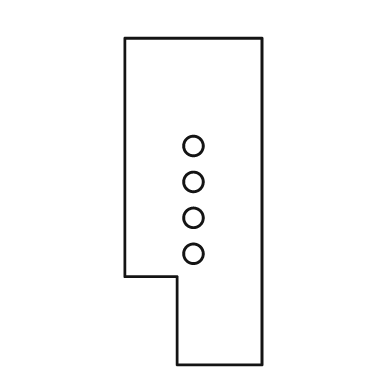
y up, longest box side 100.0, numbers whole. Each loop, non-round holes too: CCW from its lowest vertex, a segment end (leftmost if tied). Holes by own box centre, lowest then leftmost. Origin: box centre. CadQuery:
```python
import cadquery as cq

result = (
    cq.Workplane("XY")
    .moveTo(-5.0, -50.0)
    .lineTo(21.0, -50.0)
    .lineTo(21.0, 50.0)
    .lineTo(-21.0, 50.0)
    .lineTo(-21.0, -23.0)
    .lineTo(-5.0, -23.0)
    .close()
    .moveTo(0.0, -16.0)
    .circle(3.0)
    .moveTo(0.0, -5.0)
    .circle(3.0)
    .moveTo(0.0, 6.0)
    .circle(3.0)
    .moveTo(0.0, 17.0)
    .circle(3.0)
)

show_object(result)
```